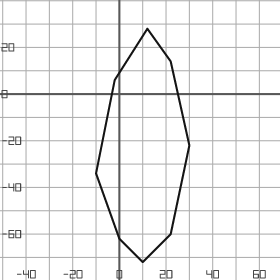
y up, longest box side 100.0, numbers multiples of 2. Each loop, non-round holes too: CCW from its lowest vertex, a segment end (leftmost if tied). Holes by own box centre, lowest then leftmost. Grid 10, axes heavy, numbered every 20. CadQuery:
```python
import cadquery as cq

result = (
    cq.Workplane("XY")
    .moveTo(10.0, -72.0)
    .lineTo(22.0, -60.0)
    .lineTo(30.0, -22.0)
    .lineTo(22.0, 14.0)
    .lineTo(12.0, 28.0)
    .lineTo(-2.0, 6.0)
    .lineTo(-10.0, -34.0)
    .lineTo(0.0, -62.0)
    .close()
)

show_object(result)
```